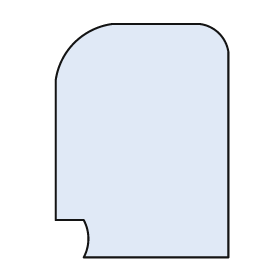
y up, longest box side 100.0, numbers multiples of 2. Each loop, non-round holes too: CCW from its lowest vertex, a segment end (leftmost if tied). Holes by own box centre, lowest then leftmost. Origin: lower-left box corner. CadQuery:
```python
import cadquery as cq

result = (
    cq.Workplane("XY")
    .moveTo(12.0, 0.0)
    .lineTo(74.0, 0.0)
    .lineTo(74.0, 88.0)
    .threePointArc((70.0, 96.0), (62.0, 100.0))
    .lineTo(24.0, 100.0)
    .threePointArc((8.0, 92.0), (0.0, 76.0))
    .lineTo(0.0, 16.0)
    .lineTo(12.0, 16.0)
    .threePointArc((14.0, 8.0), (12.0, 0.0))
    .close()
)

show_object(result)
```